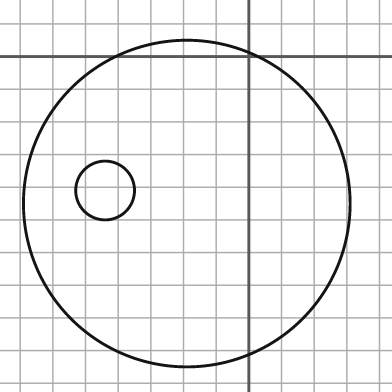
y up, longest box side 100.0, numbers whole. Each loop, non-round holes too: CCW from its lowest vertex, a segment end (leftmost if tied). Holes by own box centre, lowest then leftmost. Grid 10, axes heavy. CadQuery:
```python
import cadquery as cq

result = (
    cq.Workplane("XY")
    .moveTo(-19.0, -45.0)
    .circle(50.0)
    .moveTo(-44.0, -41.0)
    .circle(9.0)
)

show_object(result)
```